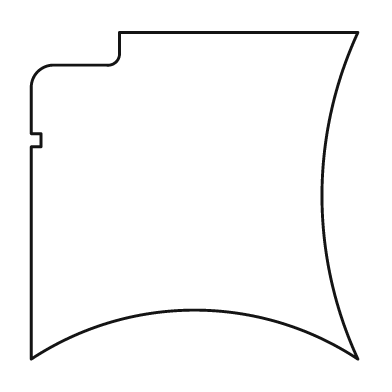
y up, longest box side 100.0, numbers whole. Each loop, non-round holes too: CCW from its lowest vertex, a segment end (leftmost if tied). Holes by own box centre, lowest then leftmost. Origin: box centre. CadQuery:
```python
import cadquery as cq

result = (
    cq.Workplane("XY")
    .moveTo(-50.0, -50.0)
    .threePointArc((0.0, -35.0), (50.0, -50.0))
    .threePointArc((39.0, 0.0), (50.0, 50.0))
    .lineTo(-23.0, 50.0)
    .lineTo(-23.0, 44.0)
    .threePointArc((-24.0, 41.0), (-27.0, 40.0))
    .lineTo(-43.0, 40.0)
    .threePointArc((-48.0, 38.0), (-50.0, 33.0))
    .lineTo(-50.0, 19.0)
    .lineTo(-47.0, 19.0)
    .lineTo(-47.0, 15.0)
    .lineTo(-50.0, 15.0)
    .close()
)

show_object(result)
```